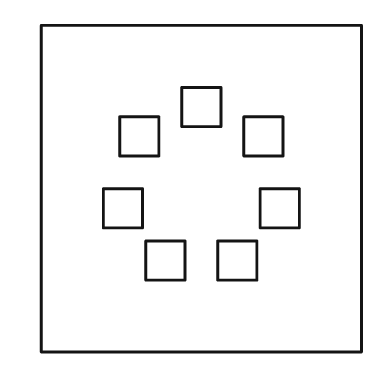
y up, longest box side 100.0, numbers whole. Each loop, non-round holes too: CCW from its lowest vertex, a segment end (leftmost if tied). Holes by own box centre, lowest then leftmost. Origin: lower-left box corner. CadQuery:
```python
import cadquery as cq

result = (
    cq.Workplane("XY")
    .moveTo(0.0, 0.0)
    .lineTo(98.0, 0.0)
    .lineTo(98.0, 100.0)
    .lineTo(0.0, 100.0)
    .close()
    .moveTo(32.0, 22.0)
    .lineTo(44.0, 22.0)
    .lineTo(44.0, 34.0)
    .lineTo(32.0, 34.0)
    .close()
    .moveTo(54.0, 22.0)
    .lineTo(66.0, 22.0)
    .lineTo(66.0, 34.0)
    .lineTo(54.0, 34.0)
    .close()
    .moveTo(19.0, 38.0)
    .lineTo(31.0, 38.0)
    .lineTo(31.0, 50.0)
    .lineTo(19.0, 50.0)
    .close()
    .moveTo(67.0, 38.0)
    .lineTo(79.0, 38.0)
    .lineTo(79.0, 50.0)
    .lineTo(67.0, 50.0)
    .close()
    .moveTo(24.0, 60.0)
    .lineTo(36.0, 60.0)
    .lineTo(36.0, 72.0)
    .lineTo(24.0, 72.0)
    .close()
    .moveTo(62.0, 60.0)
    .lineTo(74.0, 60.0)
    .lineTo(74.0, 72.0)
    .lineTo(62.0, 72.0)
    .close()
    .moveTo(43.0, 69.0)
    .lineTo(55.0, 69.0)
    .lineTo(55.0, 81.0)
    .lineTo(43.0, 81.0)
    .close()
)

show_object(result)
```